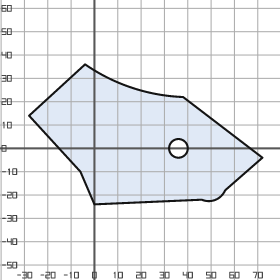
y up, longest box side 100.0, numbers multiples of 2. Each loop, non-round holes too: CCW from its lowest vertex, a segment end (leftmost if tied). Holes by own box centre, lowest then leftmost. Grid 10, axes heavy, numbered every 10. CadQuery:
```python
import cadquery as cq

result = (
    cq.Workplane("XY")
    .moveTo(0.0, -24.0)
    .lineTo(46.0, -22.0)
    .threePointArc((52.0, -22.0), (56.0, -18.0))
    .lineTo(72.0, -4.0)
    .lineTo(38.0, 22.0)
    .threePointArc((16.0, 26.0), (-4.0, 36.0))
    .lineTo(-28.0, 14.0)
    .lineTo(-6.0, -10.0)
    .close()
    .moveTo(36.0, 0.0)
    .circle(4.0)
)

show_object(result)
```